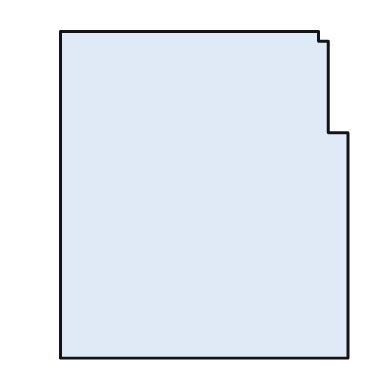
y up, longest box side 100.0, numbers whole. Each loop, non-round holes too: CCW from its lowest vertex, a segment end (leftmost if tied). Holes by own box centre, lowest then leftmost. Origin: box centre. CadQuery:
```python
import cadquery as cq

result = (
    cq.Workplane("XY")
    .moveTo(-44.0, -50.0)
    .lineTo(44.0, -50.0)
    .lineTo(44.0, 19.0)
    .lineTo(38.0, 19.0)
    .lineTo(38.0, 47.0)
    .lineTo(35.0, 47.0)
    .lineTo(35.0, 50.0)
    .lineTo(-44.0, 50.0)
    .close()
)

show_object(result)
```